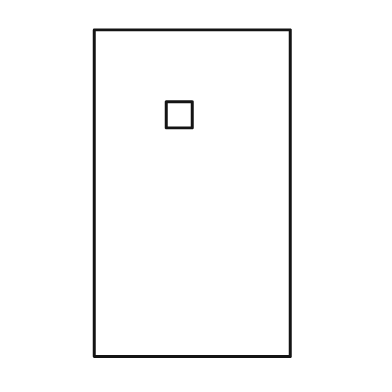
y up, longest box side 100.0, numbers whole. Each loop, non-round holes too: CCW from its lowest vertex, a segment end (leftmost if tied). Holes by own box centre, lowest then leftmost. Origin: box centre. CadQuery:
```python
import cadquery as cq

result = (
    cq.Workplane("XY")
    .moveTo(-30.0, -50.0)
    .lineTo(30.0, -50.0)
    .lineTo(30.0, 50.0)
    .lineTo(-30.0, 50.0)
    .close()
    .moveTo(-8.0, 20.0)
    .lineTo(0.0, 20.0)
    .lineTo(0.0, 28.0)
    .lineTo(-8.0, 28.0)
    .close()
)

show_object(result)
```